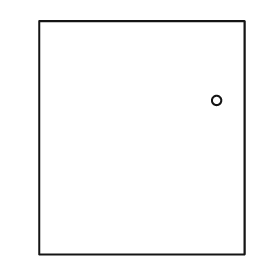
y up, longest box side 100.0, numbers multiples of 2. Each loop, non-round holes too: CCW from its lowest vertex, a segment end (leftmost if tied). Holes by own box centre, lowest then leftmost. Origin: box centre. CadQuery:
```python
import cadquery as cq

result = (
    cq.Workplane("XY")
    .moveTo(-44.0, -50.0)
    .lineTo(44.0, -50.0)
    .lineTo(44.0, 50.0)
    .lineTo(-44.0, 50.0)
    .close()
    .moveTo(32.0, 16.0)
    .circle(2.0)
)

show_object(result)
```